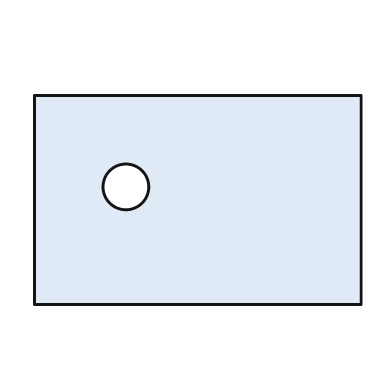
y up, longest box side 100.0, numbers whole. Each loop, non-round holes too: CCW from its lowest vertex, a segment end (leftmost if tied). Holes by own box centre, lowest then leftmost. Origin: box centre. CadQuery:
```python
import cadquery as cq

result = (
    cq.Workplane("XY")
    .moveTo(-50.0, -32.0)
    .lineTo(50.0, -32.0)
    .lineTo(50.0, 32.0)
    .lineTo(-50.0, 32.0)
    .close()
    .moveTo(-22.0, 4.0)
    .circle(7.0)
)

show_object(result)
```